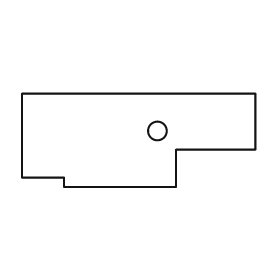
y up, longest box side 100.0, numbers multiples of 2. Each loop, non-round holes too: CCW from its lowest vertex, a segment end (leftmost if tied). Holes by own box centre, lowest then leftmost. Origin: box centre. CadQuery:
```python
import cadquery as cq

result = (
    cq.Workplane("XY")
    .moveTo(-32.0, -20.0)
    .lineTo(16.0, -20.0)
    .lineTo(16.0, -4.0)
    .lineTo(50.0, -4.0)
    .lineTo(50.0, 20.0)
    .lineTo(-50.0, 20.0)
    .lineTo(-50.0, -16.0)
    .lineTo(-32.0, -16.0)
    .close()
    .moveTo(8.0, 4.0)
    .circle(4.0)
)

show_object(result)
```